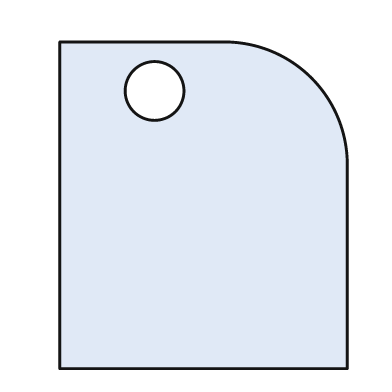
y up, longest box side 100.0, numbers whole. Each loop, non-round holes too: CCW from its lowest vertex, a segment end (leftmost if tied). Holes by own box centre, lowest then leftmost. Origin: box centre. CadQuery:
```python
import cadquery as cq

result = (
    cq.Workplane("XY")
    .moveTo(-44.0, -50.0)
    .lineTo(44.0, -50.0)
    .lineTo(44.0, 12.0)
    .threePointArc((33.0, 39.0), (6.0, 50.0))
    .lineTo(-44.0, 50.0)
    .close()
    .moveTo(-15.0, 35.0)
    .circle(9.0)
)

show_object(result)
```